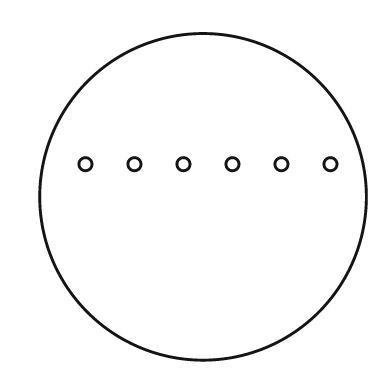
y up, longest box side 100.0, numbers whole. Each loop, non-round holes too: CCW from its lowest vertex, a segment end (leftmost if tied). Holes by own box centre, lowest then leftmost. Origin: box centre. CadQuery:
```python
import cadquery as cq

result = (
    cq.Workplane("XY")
    .moveTo(0.0, 0.0)
    .circle(50.0)
    .moveTo(-36.0, 10.0)
    .circle(2.0)
    .moveTo(-21.0, 10.0)
    .circle(2.0)
    .moveTo(-6.0, 10.0)
    .circle(2.0)
    .moveTo(9.0, 10.0)
    .circle(2.0)
    .moveTo(24.0, 10.0)
    .circle(2.0)
    .moveTo(39.0, 10.0)
    .circle(2.0)
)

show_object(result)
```